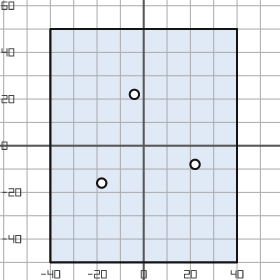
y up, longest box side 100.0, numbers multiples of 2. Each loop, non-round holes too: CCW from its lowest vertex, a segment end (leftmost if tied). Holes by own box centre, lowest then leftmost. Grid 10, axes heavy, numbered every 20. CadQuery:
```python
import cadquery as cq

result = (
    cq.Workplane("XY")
    .moveTo(-40.0, -50.0)
    .lineTo(40.0, -50.0)
    .lineTo(40.0, 50.0)
    .lineTo(-40.0, 50.0)
    .close()
    .moveTo(-18.0, -16.0)
    .circle(2.0)
    .moveTo(22.0, -8.0)
    .circle(2.0)
    .moveTo(-4.0, 22.0)
    .circle(2.0)
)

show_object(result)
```